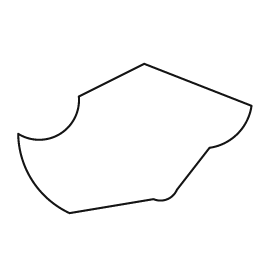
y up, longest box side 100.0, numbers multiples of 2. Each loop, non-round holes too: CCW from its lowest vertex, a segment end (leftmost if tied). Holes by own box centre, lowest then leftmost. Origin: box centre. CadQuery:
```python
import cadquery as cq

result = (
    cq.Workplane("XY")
    .moveTo(-28.0, -32.0)
    .lineTo(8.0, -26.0)
    .threePointArc((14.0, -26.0), (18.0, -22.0))
    .lineTo(32.0, -4.0)
    .threePointArc((44.0, 2.0), (50.0, 14.0))
    .lineTo(4.0, 32.0)
    .lineTo(-24.0, 18.0)
    .threePointArc((-32.0, 2.0), (-50.0, 2.0))
    .threePointArc((-44.0, -18.0), (-28.0, -32.0))
    .close()
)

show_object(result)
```